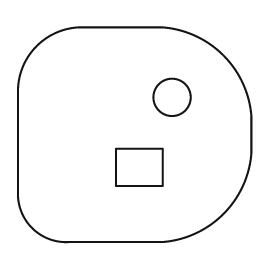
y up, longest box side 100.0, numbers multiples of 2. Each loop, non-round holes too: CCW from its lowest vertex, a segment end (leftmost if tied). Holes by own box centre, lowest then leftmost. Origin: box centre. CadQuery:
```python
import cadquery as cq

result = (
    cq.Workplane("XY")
    .moveTo(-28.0, -46.0)
    .lineTo(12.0, -46.0)
    .threePointArc((38.0, -34.0), (50.0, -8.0))
    .lineTo(50.0, 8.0)
    .threePointArc((38.0, 34.0), (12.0, 46.0))
    .lineTo(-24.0, 46.0)
    .threePointArc((-42.0, 38.0), (-50.0, 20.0))
    .lineTo(-50.0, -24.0)
    .threePointArc((-44.0, -40.0), (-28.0, -46.0))
    .close()
    .moveTo(-8.0, -22.0)
    .lineTo(12.0, -22.0)
    .lineTo(12.0, -6.0)
    .lineTo(-8.0, -6.0)
    .close()
    .moveTo(16.0, 16.0)
    .circle(8.0)
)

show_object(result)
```